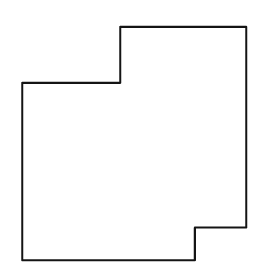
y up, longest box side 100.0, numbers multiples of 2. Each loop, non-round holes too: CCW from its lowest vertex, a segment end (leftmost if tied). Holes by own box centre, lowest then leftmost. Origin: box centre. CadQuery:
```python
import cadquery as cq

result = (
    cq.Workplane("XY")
    .moveTo(-48.0, -50.0)
    .lineTo(26.0, -50.0)
    .lineTo(26.0, -36.0)
    .lineTo(48.0, -36.0)
    .lineTo(48.0, 50.0)
    .lineTo(-6.0, 50.0)
    .lineTo(-6.0, 26.0)
    .lineTo(-48.0, 26.0)
    .close()
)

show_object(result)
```